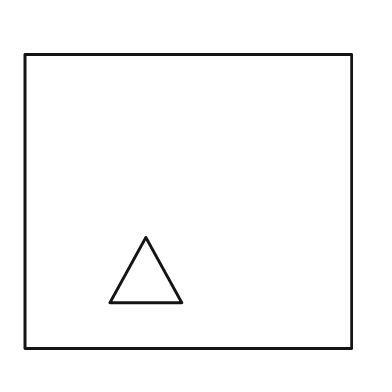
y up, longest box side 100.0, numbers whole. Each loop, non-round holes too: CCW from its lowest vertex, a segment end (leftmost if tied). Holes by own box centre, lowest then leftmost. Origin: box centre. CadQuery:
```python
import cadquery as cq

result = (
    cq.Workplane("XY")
    .moveTo(-50.0, -45.0)
    .lineTo(50.0, -45.0)
    .lineTo(50.0, 45.0)
    .lineTo(-50.0, 45.0)
    .close()
    .moveTo(-24.0, -31.0)
    .lineTo(-2.0, -31.0)
    .lineTo(-13.0, -11.0)
    .close()
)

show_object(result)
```